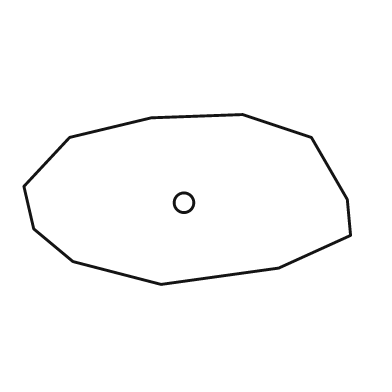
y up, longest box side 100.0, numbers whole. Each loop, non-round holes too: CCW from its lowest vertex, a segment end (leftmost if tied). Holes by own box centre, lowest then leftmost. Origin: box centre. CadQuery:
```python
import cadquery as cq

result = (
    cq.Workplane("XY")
    .moveTo(-8.0, -26.0)
    .lineTo(28.0, -21.0)
    .lineTo(50.0, -11.0)
    .lineTo(49.0, 0.0)
    .lineTo(38.0, 19.0)
    .lineTo(17.0, 26.0)
    .lineTo(-11.0, 25.0)
    .lineTo(-36.0, 19.0)
    .lineTo(-50.0, 4.0)
    .lineTo(-47.0, -9.0)
    .lineTo(-35.0, -19.0)
    .close()
    .moveTo(-1.0, -1.0)
    .circle(3.0)
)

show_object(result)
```